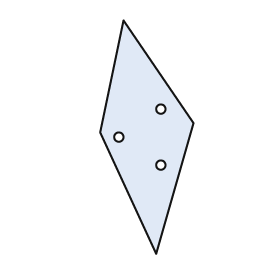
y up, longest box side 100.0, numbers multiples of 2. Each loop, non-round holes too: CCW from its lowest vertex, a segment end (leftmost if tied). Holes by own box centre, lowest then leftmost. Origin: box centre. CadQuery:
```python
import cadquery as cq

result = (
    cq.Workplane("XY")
    .moveTo(4.0, -50.0)
    .lineTo(20.0, 6.0)
    .lineTo(-10.0, 50.0)
    .lineTo(-20.0, 2.0)
    .close()
    .moveTo(6.0, -12.0)
    .circle(2.0)
    .moveTo(-12.0, 0.0)
    .circle(2.0)
    .moveTo(6.0, 12.0)
    .circle(2.0)
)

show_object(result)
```